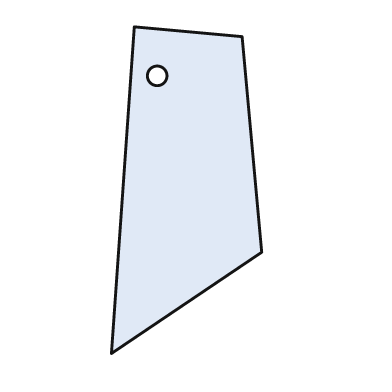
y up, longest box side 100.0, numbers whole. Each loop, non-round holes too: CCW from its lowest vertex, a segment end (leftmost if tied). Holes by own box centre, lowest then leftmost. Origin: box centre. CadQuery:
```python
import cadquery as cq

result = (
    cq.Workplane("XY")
    .moveTo(-23.0, -50.0)
    .lineTo(23.0, -19.0)
    .lineTo(17.0, 47.0)
    .lineTo(-16.0, 50.0)
    .close()
    .moveTo(-9.0, 35.0)
    .circle(3.0)
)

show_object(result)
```